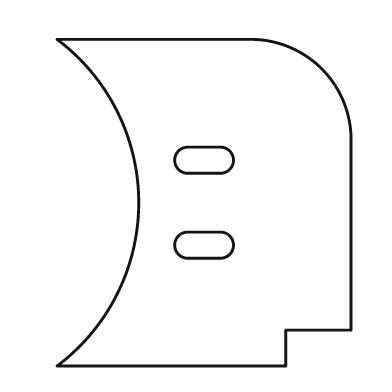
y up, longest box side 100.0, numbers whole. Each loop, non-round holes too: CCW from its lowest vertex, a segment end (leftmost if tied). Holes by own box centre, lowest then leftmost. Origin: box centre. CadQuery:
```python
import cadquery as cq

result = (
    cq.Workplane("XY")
    .moveTo(-45.0, -50.0)
    .lineTo(25.0, -50.0)
    .lineTo(25.0, -39.0)
    .lineTo(45.0, -39.0)
    .lineTo(45.0, 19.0)
    .threePointArc((36.0, 41.0), (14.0, 50.0))
    .lineTo(-45.0, 50.0)
    .threePointArc((-20.0, 0.0), (-45.0, -50.0))
    .close()
    .moveTo(-5.0, -17.0)
    .lineTo(5.0, -17.0)
    .threePointArc((9.0, -13.0), (5.0, -9.0))
    .lineTo(-5.0, -9.0)
    .threePointArc((-9.0, -13.0), (-5.0, -17.0))
    .close()
    .moveTo(-5.0, 9.0)
    .lineTo(5.0, 9.0)
    .threePointArc((9.0, 13.0), (5.0, 17.0))
    .lineTo(-5.0, 17.0)
    .threePointArc((-9.0, 13.0), (-5.0, 9.0))
    .close()
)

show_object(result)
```